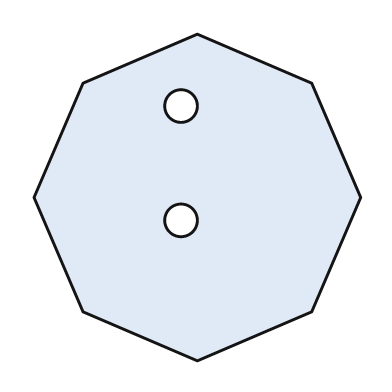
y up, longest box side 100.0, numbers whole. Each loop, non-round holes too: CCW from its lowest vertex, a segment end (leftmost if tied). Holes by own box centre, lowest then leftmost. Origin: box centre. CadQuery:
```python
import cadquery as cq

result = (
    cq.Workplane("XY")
    .moveTo(0.0, -50.0)
    .lineTo(35.0, -35.0)
    .lineTo(50.0, 0.0)
    .lineTo(35.0, 35.0)
    .lineTo(0.0, 50.0)
    .lineTo(-35.0, 35.0)
    .lineTo(-50.0, 0.0)
    .lineTo(-35.0, -35.0)
    .close()
    .moveTo(-5.0, -7.0)
    .circle(5.0)
    .moveTo(-5.0, 28.0)
    .circle(5.0)
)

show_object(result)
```